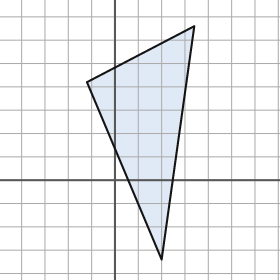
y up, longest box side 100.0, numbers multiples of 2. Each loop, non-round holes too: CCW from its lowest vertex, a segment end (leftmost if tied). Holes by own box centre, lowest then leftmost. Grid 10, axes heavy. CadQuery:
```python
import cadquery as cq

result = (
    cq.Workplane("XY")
    .moveTo(20.0, -34.0)
    .lineTo(34.0, 66.0)
    .lineTo(-12.0, 42.0)
    .close()
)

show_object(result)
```